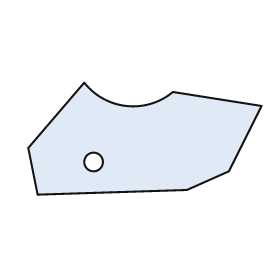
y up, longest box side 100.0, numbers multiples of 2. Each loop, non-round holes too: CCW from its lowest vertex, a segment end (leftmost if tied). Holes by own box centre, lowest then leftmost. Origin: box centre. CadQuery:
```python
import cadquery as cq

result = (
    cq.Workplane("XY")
    .moveTo(-46.0, -24.0)
    .lineTo(18.0, -22.0)
    .lineTo(36.0, -14.0)
    .lineTo(50.0, 14.0)
    .lineTo(12.0, 20.0)
    .threePointArc((-8.0, 14.0), (-26.0, 24.0))
    .lineTo(-50.0, -4.0)
    .close()
    .moveTo(-22.0, -10.0)
    .circle(4.0)
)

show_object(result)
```